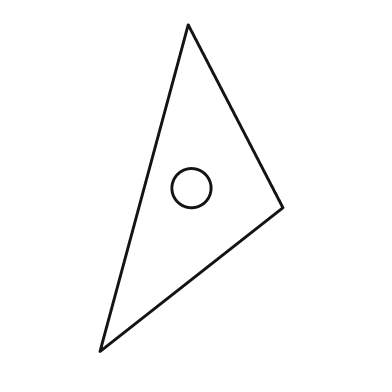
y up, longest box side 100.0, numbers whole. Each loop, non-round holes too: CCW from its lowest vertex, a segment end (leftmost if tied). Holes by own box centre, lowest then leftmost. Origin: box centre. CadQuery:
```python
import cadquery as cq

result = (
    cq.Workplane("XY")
    .moveTo(-28.0, -50.0)
    .lineTo(28.0, -6.0)
    .lineTo(-1.0, 50.0)
    .close()
    .moveTo(0.0, 0.0)
    .circle(6.0)
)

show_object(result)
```